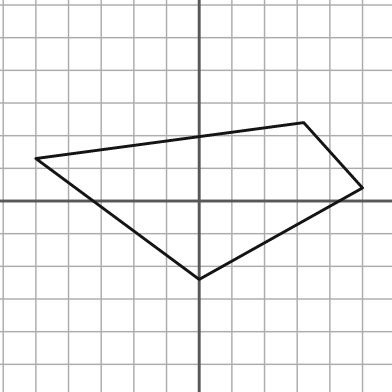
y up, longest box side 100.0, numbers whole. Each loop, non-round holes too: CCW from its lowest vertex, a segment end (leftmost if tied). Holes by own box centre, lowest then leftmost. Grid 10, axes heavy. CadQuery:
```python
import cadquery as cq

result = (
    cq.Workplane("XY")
    .moveTo(0.0, -24.0)
    .lineTo(50.0, 4.0)
    .lineTo(32.0, 24.0)
    .lineTo(-50.0, 13.0)
    .close()
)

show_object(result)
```